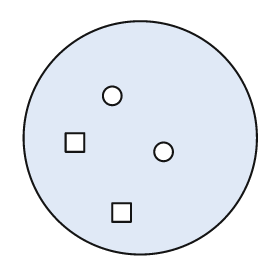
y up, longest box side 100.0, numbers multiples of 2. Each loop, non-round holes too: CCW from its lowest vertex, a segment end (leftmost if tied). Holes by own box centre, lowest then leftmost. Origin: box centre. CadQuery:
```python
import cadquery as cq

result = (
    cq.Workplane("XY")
    .moveTo(0.0, 0.0)
    .circle(50.0)
    .moveTo(-12.0, -36.0)
    .lineTo(-4.0, -36.0)
    .lineTo(-4.0, -28.0)
    .lineTo(-12.0, -28.0)
    .close()
    .moveTo(10.0, -6.0)
    .circle(4.0)
    .moveTo(-32.0, -6.0)
    .lineTo(-24.0, -6.0)
    .lineTo(-24.0, 2.0)
    .lineTo(-32.0, 2.0)
    .close()
    .moveTo(-12.0, 18.0)
    .circle(4.0)
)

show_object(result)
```